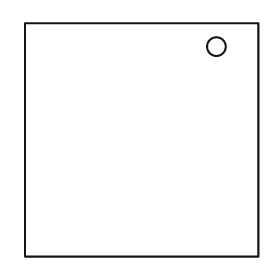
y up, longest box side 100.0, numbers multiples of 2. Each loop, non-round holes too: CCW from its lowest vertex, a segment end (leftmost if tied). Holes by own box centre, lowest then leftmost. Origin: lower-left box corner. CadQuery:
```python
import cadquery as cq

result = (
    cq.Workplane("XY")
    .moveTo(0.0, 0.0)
    .lineTo(100.0, 0.0)
    .lineTo(100.0, 100.0)
    .lineTo(0.0, 100.0)
    .close()
    .moveTo(82.0, 90.0)
    .circle(4.0)
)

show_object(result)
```